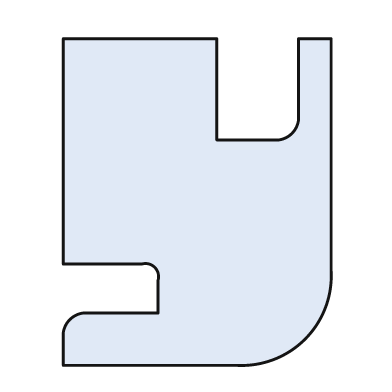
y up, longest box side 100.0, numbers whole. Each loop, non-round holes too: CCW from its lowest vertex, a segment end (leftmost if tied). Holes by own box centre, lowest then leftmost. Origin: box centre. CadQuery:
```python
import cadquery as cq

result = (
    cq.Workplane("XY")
    .moveTo(-41.0, -50.0)
    .lineTo(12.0, -50.0)
    .threePointArc((33.0, -42.0), (41.0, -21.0))
    .lineTo(41.0, 50.0)
    .lineTo(31.0, 50.0)
    .lineTo(31.0, 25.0)
    .threePointArc((29.0, 21.0), (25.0, 19.0))
    .lineTo(6.0, 19.0)
    .lineTo(6.0, 50.0)
    .lineTo(-41.0, 50.0)
    .lineTo(-41.0, -19.0)
    .lineTo(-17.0, -19.0)
    .threePointArc((-13.0, -20.0), (-12.0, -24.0))
    .lineTo(-12.0, -34.0)
    .lineTo(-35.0, -34.0)
    .threePointArc((-39.0, -36.0), (-41.0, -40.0))
    .close()
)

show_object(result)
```